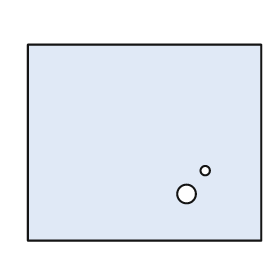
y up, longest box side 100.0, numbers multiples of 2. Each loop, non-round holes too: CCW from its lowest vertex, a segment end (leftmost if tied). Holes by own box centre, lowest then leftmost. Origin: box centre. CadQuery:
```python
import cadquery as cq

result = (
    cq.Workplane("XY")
    .moveTo(-50.0, -42.0)
    .lineTo(50.0, -42.0)
    .lineTo(50.0, 42.0)
    .lineTo(-50.0, 42.0)
    .close()
    .moveTo(18.0, -22.0)
    .circle(4.0)
    .moveTo(26.0, -12.0)
    .circle(2.0)
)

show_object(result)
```